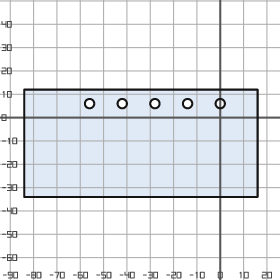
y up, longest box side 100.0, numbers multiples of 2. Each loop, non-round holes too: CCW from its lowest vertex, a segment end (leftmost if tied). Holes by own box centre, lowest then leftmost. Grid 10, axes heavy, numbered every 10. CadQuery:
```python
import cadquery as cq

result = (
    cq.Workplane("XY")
    .moveTo(-84.0, -34.0)
    .lineTo(16.0, -34.0)
    .lineTo(16.0, 12.0)
    .lineTo(-84.0, 12.0)
    .close()
    .moveTo(-56.0, 6.0)
    .circle(2.0)
    .moveTo(-42.0, 6.0)
    .circle(2.0)
    .moveTo(-28.0, 6.0)
    .circle(2.0)
    .moveTo(-14.0, 6.0)
    .circle(2.0)
    .moveTo(0.0, 6.0)
    .circle(2.0)
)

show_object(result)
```